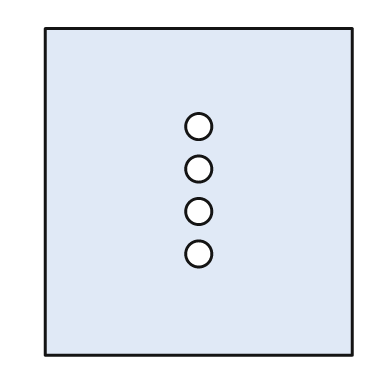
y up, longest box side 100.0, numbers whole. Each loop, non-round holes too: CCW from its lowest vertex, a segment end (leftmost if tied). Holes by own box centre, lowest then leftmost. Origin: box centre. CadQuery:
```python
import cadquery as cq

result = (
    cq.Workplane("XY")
    .moveTo(-47.0, -50.0)
    .lineTo(47.0, -50.0)
    .lineTo(47.0, 50.0)
    .lineTo(-47.0, 50.0)
    .close()
    .moveTo(0.0, -19.0)
    .circle(4.0)
    .moveTo(0.0, -6.0)
    .circle(4.0)
    .moveTo(0.0, 7.0)
    .circle(4.0)
    .moveTo(0.0, 20.0)
    .circle(4.0)
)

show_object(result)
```